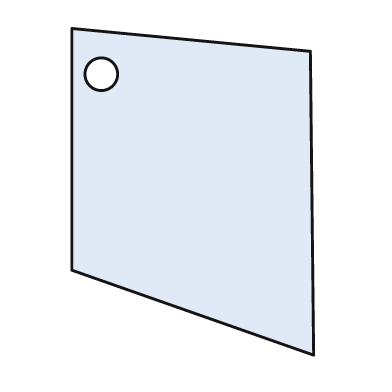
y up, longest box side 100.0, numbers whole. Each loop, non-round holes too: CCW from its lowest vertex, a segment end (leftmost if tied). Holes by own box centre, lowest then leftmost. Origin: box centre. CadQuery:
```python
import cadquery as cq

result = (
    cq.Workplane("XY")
    .moveTo(37.0, -50.0)
    .lineTo(36.0, 43.0)
    .lineTo(-37.0, 50.0)
    .lineTo(-37.0, -24.0)
    .close()
    .moveTo(-28.0, 36.0)
    .circle(5.0)
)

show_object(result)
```